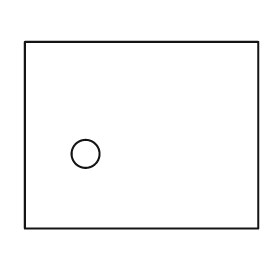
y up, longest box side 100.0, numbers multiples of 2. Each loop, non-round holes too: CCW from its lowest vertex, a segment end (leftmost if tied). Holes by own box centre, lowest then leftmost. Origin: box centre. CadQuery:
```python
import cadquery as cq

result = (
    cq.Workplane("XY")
    .moveTo(-50.0, -40.0)
    .lineTo(50.0, -40.0)
    .lineTo(50.0, 40.0)
    .lineTo(-50.0, 40.0)
    .close()
    .moveTo(-24.0, -8.0)
    .circle(6.0)
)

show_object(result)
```